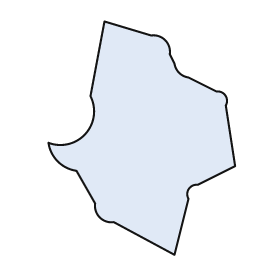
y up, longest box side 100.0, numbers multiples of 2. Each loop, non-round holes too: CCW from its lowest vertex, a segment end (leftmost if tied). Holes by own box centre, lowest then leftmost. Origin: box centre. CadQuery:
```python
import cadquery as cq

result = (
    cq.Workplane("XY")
    .moveTo(14.0, -50.0)
    .lineTo(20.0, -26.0)
    .threePointArc((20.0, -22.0), (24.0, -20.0))
    .lineTo(40.0, -12.0)
    .lineTo(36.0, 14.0)
    .threePointArc((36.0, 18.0), (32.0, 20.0))
    .lineTo(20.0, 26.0)
    .threePointArc((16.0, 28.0), (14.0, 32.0))
    .lineTo(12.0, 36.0)
    .threePointArc((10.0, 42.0), (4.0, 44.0))
    .lineTo(-16.0, 50.0)
    .lineTo(-22.0, 18.0)
    .threePointArc((-24.0, 2.0), (-40.0, -2.0))
    .threePointArc((-36.0, -10.0), (-28.0, -14.0))
    .lineTo(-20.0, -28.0)
    .threePointArc((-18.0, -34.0), (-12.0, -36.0))
    .close()
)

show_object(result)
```